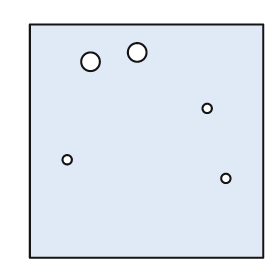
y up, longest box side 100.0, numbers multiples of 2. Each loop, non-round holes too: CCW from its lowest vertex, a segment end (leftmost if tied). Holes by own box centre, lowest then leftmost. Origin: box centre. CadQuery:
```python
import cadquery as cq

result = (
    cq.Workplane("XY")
    .moveTo(-50.0, -50.0)
    .lineTo(50.0, -50.0)
    .lineTo(50.0, 50.0)
    .lineTo(-50.0, 50.0)
    .close()
    .moveTo(34.0, -16.0)
    .circle(2.0)
    .moveTo(-34.0, -8.0)
    .circle(2.0)
    .moveTo(26.0, 14.0)
    .circle(2.0)
    .moveTo(-24.0, 34.0)
    .circle(4.0)
    .moveTo(-4.0, 38.0)
    .circle(4.0)
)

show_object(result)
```